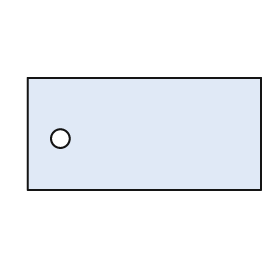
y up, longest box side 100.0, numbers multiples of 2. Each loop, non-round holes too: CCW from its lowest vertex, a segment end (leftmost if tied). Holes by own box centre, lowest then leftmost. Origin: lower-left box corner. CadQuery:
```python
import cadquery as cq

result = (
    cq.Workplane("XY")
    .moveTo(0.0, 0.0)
    .lineTo(100.0, 0.0)
    .lineTo(100.0, 48.0)
    .lineTo(0.0, 48.0)
    .close()
    .moveTo(14.0, 22.0)
    .circle(4.0)
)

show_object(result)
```